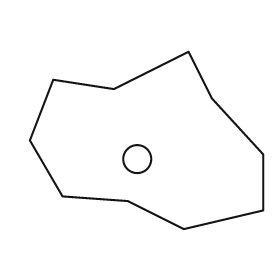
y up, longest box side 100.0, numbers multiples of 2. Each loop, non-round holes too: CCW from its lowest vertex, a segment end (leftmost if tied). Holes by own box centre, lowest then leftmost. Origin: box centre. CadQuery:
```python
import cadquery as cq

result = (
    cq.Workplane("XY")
    .moveTo(16.0, -38.0)
    .lineTo(50.0, -30.0)
    .lineTo(50.0, -6.0)
    .lineTo(28.0, 18.0)
    .lineTo(18.0, 38.0)
    .lineTo(-14.0, 22.0)
    .lineTo(-40.0, 26.0)
    .lineTo(-50.0, 0.0)
    .lineTo(-36.0, -24.0)
    .lineTo(-8.0, -26.0)
    .close()
    .moveTo(-4.0, -8.0)
    .circle(6.0)
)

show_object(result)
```